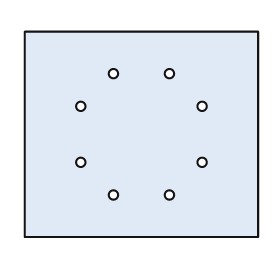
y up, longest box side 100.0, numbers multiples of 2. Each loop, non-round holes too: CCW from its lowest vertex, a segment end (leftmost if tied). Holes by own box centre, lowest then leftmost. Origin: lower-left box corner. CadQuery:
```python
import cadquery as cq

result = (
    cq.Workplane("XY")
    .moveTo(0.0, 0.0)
    .lineTo(100.0, 0.0)
    .lineTo(100.0, 88.0)
    .lineTo(0.0, 88.0)
    .close()
    .moveTo(38.0, 18.0)
    .circle(2.0)
    .moveTo(62.0, 18.0)
    .circle(2.0)
    .moveTo(24.0, 32.0)
    .circle(2.0)
    .moveTo(76.0, 32.0)
    .circle(2.0)
    .moveTo(24.0, 56.0)
    .circle(2.0)
    .moveTo(76.0, 56.0)
    .circle(2.0)
    .moveTo(38.0, 70.0)
    .circle(2.0)
    .moveTo(62.0, 70.0)
    .circle(2.0)
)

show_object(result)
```